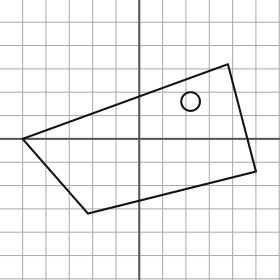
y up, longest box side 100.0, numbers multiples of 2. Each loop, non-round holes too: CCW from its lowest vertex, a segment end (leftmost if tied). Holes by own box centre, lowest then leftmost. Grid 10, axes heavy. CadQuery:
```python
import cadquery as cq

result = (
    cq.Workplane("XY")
    .moveTo(-22.0, -32.0)
    .lineTo(50.0, -14.0)
    .lineTo(38.0, 32.0)
    .lineTo(-50.0, 0.0)
    .close()
    .moveTo(22.0, 16.0)
    .circle(4.0)
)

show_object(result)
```